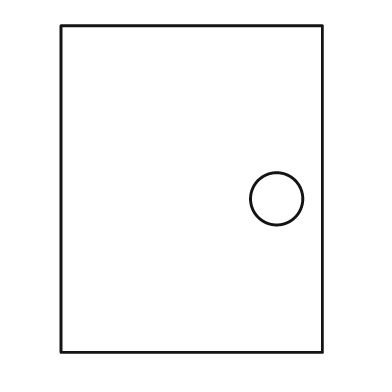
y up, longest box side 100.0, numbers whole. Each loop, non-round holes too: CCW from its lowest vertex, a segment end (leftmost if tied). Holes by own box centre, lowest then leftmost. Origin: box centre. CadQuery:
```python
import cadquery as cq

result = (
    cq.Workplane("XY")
    .moveTo(-40.0, -50.0)
    .lineTo(40.0, -50.0)
    .lineTo(40.0, 50.0)
    .lineTo(-40.0, 50.0)
    .close()
    .moveTo(26.0, -3.0)
    .circle(8.0)
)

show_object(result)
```